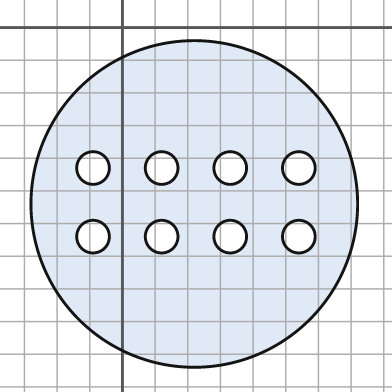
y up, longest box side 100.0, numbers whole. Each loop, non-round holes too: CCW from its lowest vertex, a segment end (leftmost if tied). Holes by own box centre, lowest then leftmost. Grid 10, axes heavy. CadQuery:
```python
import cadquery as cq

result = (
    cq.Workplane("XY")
    .moveTo(22.0, -54.0)
    .circle(50.0)
    .moveTo(-9.0, -64.0)
    .circle(5.0)
    .moveTo(12.0, -64.0)
    .circle(5.0)
    .moveTo(33.0, -64.0)
    .circle(5.0)
    .moveTo(54.0, -64.0)
    .circle(5.0)
    .moveTo(-9.0, -43.0)
    .circle(5.0)
    .moveTo(12.0, -43.0)
    .circle(5.0)
    .moveTo(33.0, -43.0)
    .circle(5.0)
    .moveTo(54.0, -43.0)
    .circle(5.0)
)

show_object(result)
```